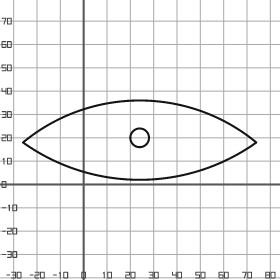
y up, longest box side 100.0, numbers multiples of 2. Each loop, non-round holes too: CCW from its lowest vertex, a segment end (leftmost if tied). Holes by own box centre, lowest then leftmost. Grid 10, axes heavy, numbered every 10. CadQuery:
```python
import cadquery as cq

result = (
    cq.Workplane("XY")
    .moveTo(-26.0, 18.0)
    .threePointArc((24.0, 2.0), (74.0, 18.0))
    .threePointArc((24.0, 36.0), (-26.0, 18.0))
    .close()
    .moveTo(24.0, 20.0)
    .circle(4.0)
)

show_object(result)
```